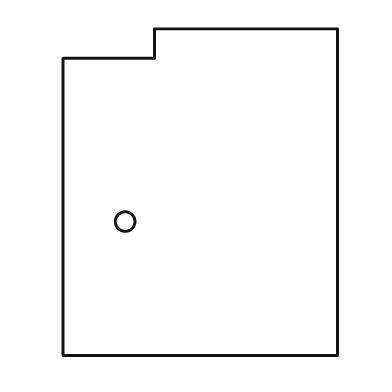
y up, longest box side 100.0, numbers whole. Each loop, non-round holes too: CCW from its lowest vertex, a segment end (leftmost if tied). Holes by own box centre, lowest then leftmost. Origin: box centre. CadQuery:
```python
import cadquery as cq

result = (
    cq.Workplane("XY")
    .moveTo(-42.0, -50.0)
    .lineTo(42.0, -50.0)
    .lineTo(42.0, 50.0)
    .lineTo(-14.0, 50.0)
    .lineTo(-14.0, 41.0)
    .lineTo(-42.0, 41.0)
    .close()
    .moveTo(-23.0, -9.0)
    .circle(3.0)
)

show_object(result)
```